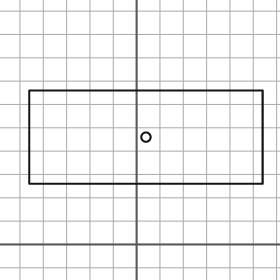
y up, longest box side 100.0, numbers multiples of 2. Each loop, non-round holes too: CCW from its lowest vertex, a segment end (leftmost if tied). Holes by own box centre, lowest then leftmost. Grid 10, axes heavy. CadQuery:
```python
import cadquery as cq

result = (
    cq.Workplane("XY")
    .moveTo(-46.0, 26.0)
    .lineTo(54.0, 26.0)
    .lineTo(54.0, 66.0)
    .lineTo(-46.0, 66.0)
    .close()
    .moveTo(4.0, 46.0)
    .circle(2.0)
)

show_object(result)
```